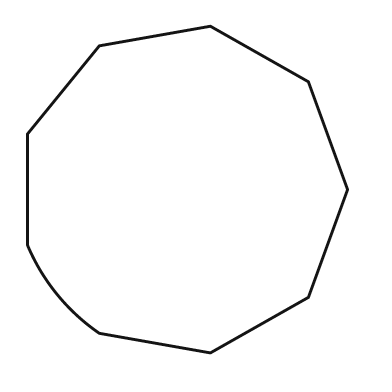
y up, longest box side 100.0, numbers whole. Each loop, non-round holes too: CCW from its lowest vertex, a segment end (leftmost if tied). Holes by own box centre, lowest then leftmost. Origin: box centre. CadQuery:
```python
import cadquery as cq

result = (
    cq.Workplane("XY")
    .moveTo(7.0, -50.0)
    .lineTo(37.0, -33.0)
    .lineTo(49.0, 0.0)
    .lineTo(37.0, 33.0)
    .lineTo(7.0, 50.0)
    .lineTo(-27.0, 44.0)
    .lineTo(-49.0, 17.0)
    .lineTo(-49.0, -17.0)
    .threePointArc((-40.0, -32.0), (-27.0, -44.0))
    .close()
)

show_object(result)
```